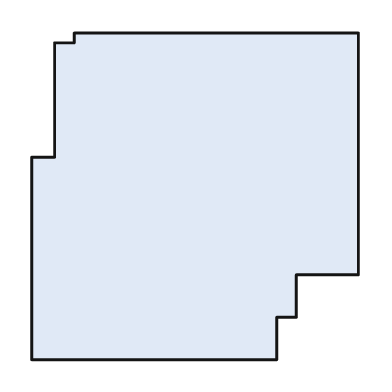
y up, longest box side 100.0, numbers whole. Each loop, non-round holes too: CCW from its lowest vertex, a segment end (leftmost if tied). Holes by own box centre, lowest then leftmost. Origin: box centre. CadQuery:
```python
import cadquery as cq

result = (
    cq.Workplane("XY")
    .moveTo(-50.0, -50.0)
    .lineTo(25.0, -50.0)
    .lineTo(25.0, -37.0)
    .lineTo(31.0, -37.0)
    .lineTo(31.0, -24.0)
    .lineTo(50.0, -24.0)
    .lineTo(50.0, 50.0)
    .lineTo(-37.0, 50.0)
    .lineTo(-37.0, 47.0)
    .lineTo(-43.0, 47.0)
    .lineTo(-43.0, 12.0)
    .lineTo(-50.0, 12.0)
    .close()
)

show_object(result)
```